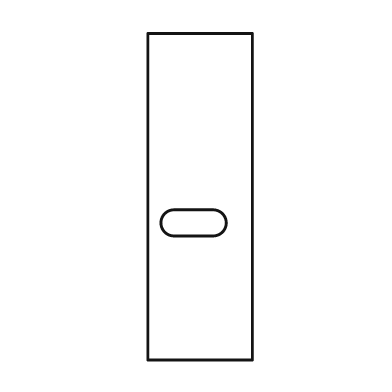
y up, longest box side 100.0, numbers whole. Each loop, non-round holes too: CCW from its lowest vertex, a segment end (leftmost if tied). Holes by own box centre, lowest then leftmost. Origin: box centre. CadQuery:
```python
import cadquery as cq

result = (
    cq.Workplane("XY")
    .moveTo(-16.0, -50.0)
    .lineTo(16.0, -50.0)
    .lineTo(16.0, 50.0)
    .lineTo(-16.0, 50.0)
    .close()
    .moveTo(-8.0, -12.0)
    .lineTo(4.0, -12.0)
    .threePointArc((8.0, -8.0), (4.0, -4.0))
    .lineTo(-8.0, -4.0)
    .threePointArc((-12.0, -8.0), (-8.0, -12.0))
    .close()
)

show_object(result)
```